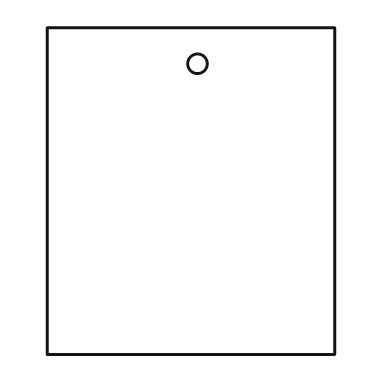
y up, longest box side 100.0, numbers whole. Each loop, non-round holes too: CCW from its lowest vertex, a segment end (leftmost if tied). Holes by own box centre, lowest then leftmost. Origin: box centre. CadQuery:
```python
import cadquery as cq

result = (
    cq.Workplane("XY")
    .moveTo(-44.0, -50.0)
    .lineTo(44.0, -50.0)
    .lineTo(44.0, 50.0)
    .lineTo(-44.0, 50.0)
    .close()
    .moveTo(2.0, 39.0)
    .circle(3.0)
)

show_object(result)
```